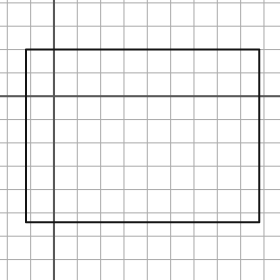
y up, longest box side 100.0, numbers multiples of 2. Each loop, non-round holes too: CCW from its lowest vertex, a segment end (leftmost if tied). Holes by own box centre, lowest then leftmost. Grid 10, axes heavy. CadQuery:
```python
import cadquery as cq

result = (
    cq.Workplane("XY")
    .moveTo(-12.0, -54.0)
    .lineTo(88.0, -54.0)
    .lineTo(88.0, 20.0)
    .lineTo(-12.0, 20.0)
    .close()
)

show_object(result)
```